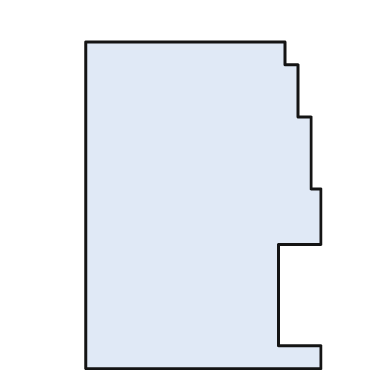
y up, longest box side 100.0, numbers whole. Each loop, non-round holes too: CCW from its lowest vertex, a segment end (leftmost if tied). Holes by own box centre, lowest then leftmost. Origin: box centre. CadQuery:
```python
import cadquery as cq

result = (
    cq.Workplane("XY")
    .moveTo(-36.0, -50.0)
    .lineTo(36.0, -50.0)
    .lineTo(36.0, -43.0)
    .lineTo(23.0, -43.0)
    .lineTo(23.0, -12.0)
    .lineTo(36.0, -12.0)
    .lineTo(36.0, 5.0)
    .lineTo(33.0, 5.0)
    .lineTo(33.0, 27.0)
    .lineTo(29.0, 27.0)
    .lineTo(29.0, 43.0)
    .lineTo(25.0, 43.0)
    .lineTo(25.0, 50.0)
    .lineTo(-36.0, 50.0)
    .close()
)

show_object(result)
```